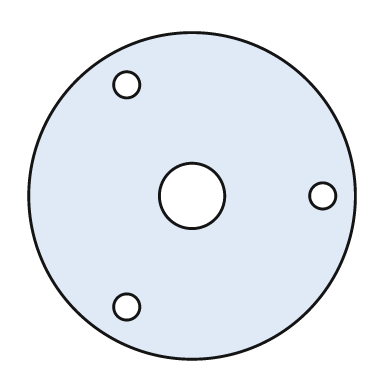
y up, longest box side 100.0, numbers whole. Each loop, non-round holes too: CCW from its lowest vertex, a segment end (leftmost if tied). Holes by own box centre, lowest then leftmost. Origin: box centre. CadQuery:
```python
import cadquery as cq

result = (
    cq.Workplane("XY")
    .moveTo(0.0, 0.0)
    .circle(50.0)
    .moveTo(-20.0, -34.0)
    .circle(4.0)
    .moveTo(0.0, 0.0)
    .circle(10.0)
    .moveTo(40.0, 0.0)
    .circle(4.0)
    .moveTo(-20.0, 34.0)
    .circle(4.0)
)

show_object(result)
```